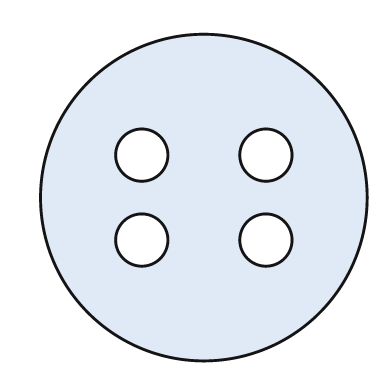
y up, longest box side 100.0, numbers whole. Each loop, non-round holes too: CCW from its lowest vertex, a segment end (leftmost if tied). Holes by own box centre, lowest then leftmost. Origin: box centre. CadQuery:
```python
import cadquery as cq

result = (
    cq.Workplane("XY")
    .moveTo(0.0, 0.0)
    .circle(50.0)
    .moveTo(-19.0, -13.0)
    .circle(8.0)
    .moveTo(19.0, -13.0)
    .circle(8.0)
    .moveTo(-19.0, 13.0)
    .circle(8.0)
    .moveTo(19.0, 13.0)
    .circle(8.0)
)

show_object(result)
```